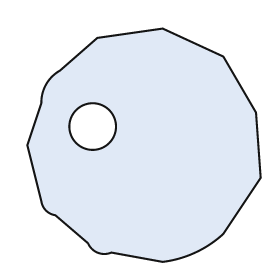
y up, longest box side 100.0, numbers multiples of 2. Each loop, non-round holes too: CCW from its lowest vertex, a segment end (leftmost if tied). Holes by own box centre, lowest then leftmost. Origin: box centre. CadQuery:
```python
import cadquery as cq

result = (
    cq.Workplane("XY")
    .moveTo(8.0, -50.0)
    .threePointArc((22.0, -46.0), (34.0, -38.0))
    .lineTo(50.0, -14.0)
    .lineTo(48.0, 14.0)
    .lineTo(34.0, 38.0)
    .lineTo(8.0, 50.0)
    .lineTo(-20.0, 46.0)
    .lineTo(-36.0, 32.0)
    .threePointArc((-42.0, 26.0), (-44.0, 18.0))
    .lineTo(-50.0, 0.0)
    .lineTo(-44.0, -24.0)
    .threePointArc((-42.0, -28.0), (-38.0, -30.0))
    .lineTo(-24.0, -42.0)
    .threePointArc((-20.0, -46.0), (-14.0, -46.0))
    .close()
    .moveTo(-22.0, 8.0)
    .circle(10.0)
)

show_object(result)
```